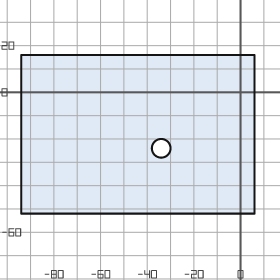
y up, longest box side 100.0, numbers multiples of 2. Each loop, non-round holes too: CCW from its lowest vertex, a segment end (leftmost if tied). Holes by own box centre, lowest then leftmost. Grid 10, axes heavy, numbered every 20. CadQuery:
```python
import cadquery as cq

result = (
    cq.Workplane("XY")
    .moveTo(-94.0, -52.0)
    .lineTo(6.0, -52.0)
    .lineTo(6.0, 16.0)
    .lineTo(-94.0, 16.0)
    .close()
    .moveTo(-34.0, -24.0)
    .circle(4.0)
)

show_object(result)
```